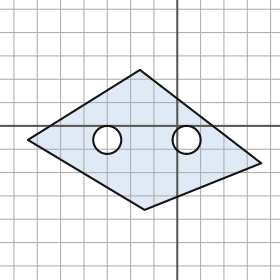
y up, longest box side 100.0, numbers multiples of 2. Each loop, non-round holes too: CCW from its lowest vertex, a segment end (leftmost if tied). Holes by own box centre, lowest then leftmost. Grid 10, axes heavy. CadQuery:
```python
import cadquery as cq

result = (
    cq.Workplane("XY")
    .moveTo(-14.0, -36.0)
    .lineTo(36.0, -16.0)
    .lineTo(-16.0, 24.0)
    .lineTo(-64.0, -6.0)
    .close()
    .moveTo(-30.0, -6.0)
    .circle(6.0)
    .moveTo(4.0, -6.0)
    .circle(6.0)
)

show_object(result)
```